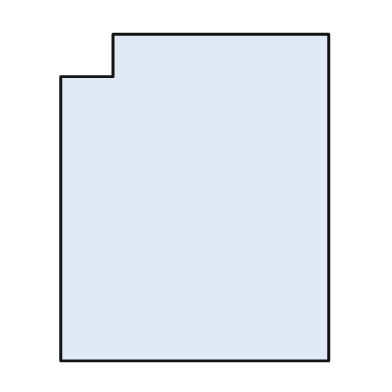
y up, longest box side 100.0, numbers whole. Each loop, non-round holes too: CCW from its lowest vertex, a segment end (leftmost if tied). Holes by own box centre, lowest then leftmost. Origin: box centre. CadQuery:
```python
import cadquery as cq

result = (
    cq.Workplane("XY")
    .moveTo(-41.0, -50.0)
    .lineTo(41.0, -50.0)
    .lineTo(41.0, 50.0)
    .lineTo(-25.0, 50.0)
    .lineTo(-25.0, 37.0)
    .lineTo(-41.0, 37.0)
    .close()
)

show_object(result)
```